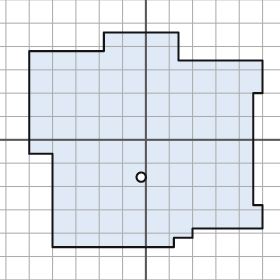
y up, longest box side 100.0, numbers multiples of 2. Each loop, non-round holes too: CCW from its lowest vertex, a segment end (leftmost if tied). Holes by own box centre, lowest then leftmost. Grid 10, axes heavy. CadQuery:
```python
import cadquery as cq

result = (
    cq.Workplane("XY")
    .moveTo(-40.0, -46.0)
    .lineTo(12.0, -46.0)
    .lineTo(12.0, -42.0)
    .lineTo(20.0, -42.0)
    .lineTo(20.0, -38.0)
    .lineTo(50.0, -38.0)
    .lineTo(50.0, -28.0)
    .lineTo(46.0, -28.0)
    .lineTo(46.0, 20.0)
    .lineTo(50.0, 20.0)
    .lineTo(50.0, 34.0)
    .lineTo(14.0, 34.0)
    .lineTo(14.0, 46.0)
    .lineTo(-18.0, 46.0)
    .lineTo(-18.0, 38.0)
    .lineTo(-50.0, 38.0)
    .lineTo(-50.0, -6.0)
    .lineTo(-40.0, -6.0)
    .close()
    .moveTo(-2.0, -16.0)
    .circle(2.0)
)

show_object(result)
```